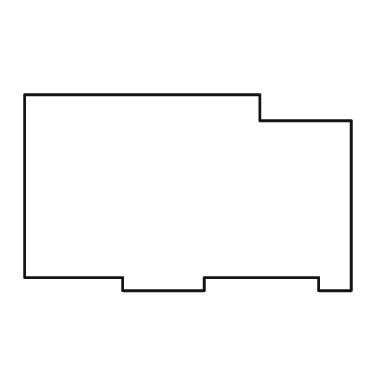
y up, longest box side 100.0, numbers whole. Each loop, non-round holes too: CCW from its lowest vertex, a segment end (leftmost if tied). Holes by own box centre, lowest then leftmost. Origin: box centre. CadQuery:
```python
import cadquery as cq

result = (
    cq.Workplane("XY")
    .moveTo(-20.0, -30.0)
    .lineTo(5.0, -30.0)
    .lineTo(5.0, -26.0)
    .lineTo(40.0, -26.0)
    .lineTo(40.0, -30.0)
    .lineTo(50.0, -30.0)
    .lineTo(50.0, 22.0)
    .lineTo(22.0, 22.0)
    .lineTo(22.0, 30.0)
    .lineTo(-50.0, 30.0)
    .lineTo(-50.0, -26.0)
    .lineTo(-20.0, -26.0)
    .close()
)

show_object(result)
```